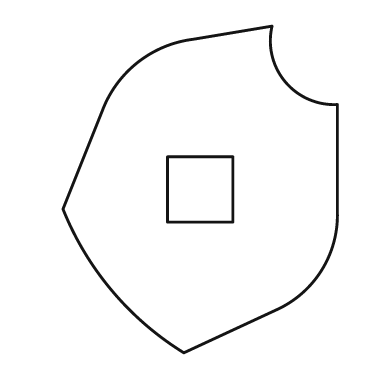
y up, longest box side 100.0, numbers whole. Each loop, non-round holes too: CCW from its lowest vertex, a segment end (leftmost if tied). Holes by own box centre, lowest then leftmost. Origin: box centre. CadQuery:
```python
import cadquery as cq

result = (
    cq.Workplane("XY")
    .moveTo(-5.0, -50.0)
    .lineTo(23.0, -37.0)
    .threePointArc((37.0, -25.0), (42.0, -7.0))
    .lineTo(42.0, 26.0)
    .threePointArc((26.0, 33.0), (22.0, 50.0))
    .lineTo(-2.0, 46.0)
    .threePointArc((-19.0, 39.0), (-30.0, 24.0))
    .lineTo(-42.0, -6.0)
    .threePointArc((-27.0, -31.0), (-5.0, -50.0))
    .close()
    .moveTo(-10.0, -10.0)
    .lineTo(10.0, -10.0)
    .lineTo(10.0, 10.0)
    .lineTo(-10.0, 10.0)
    .close()
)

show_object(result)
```